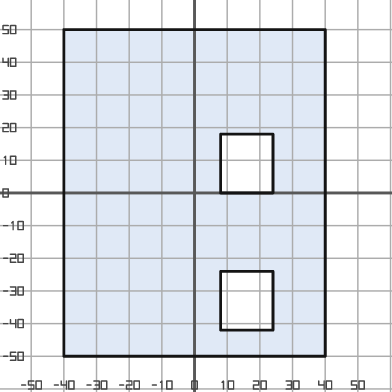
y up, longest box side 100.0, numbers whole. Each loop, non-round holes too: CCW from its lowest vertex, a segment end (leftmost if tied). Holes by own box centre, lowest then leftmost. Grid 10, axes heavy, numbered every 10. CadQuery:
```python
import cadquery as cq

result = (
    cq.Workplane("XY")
    .moveTo(-40.0, -50.0)
    .lineTo(40.0, -50.0)
    .lineTo(40.0, 50.0)
    .lineTo(-40.0, 50.0)
    .close()
    .moveTo(8.0, -42.0)
    .lineTo(24.0, -42.0)
    .lineTo(24.0, -24.0)
    .lineTo(8.0, -24.0)
    .close()
    .moveTo(8.0, 0.0)
    .lineTo(24.0, 0.0)
    .lineTo(24.0, 18.0)
    .lineTo(8.0, 18.0)
    .close()
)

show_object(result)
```